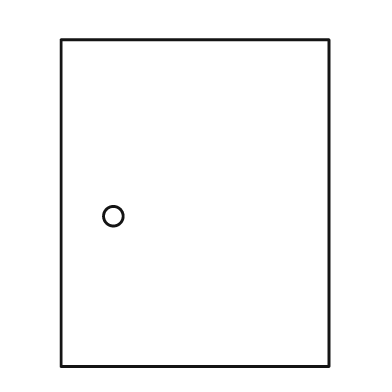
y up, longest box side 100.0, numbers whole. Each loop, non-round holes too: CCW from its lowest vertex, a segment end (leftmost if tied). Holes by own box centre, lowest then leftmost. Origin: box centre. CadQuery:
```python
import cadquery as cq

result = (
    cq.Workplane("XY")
    .moveTo(-41.0, -50.0)
    .lineTo(41.0, -50.0)
    .lineTo(41.0, 50.0)
    .lineTo(-41.0, 50.0)
    .close()
    .moveTo(-25.0, -4.0)
    .circle(3.0)
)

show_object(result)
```